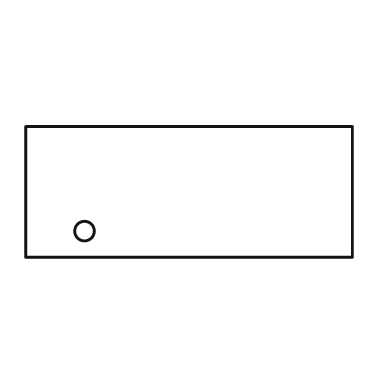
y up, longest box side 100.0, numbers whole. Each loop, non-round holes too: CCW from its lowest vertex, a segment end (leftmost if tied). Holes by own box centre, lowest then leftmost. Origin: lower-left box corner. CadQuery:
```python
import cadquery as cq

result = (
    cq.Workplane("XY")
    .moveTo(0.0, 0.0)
    .lineTo(100.0, 0.0)
    .lineTo(100.0, 40.0)
    .lineTo(0.0, 40.0)
    .close()
    .moveTo(18.0, 8.0)
    .circle(3.0)
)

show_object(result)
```